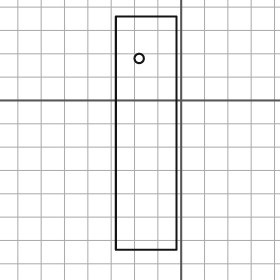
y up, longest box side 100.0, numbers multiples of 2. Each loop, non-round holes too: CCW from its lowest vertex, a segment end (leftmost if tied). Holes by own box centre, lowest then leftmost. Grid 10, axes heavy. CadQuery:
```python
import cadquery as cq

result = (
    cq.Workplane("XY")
    .moveTo(-28.0, -64.0)
    .lineTo(-2.0, -64.0)
    .lineTo(-2.0, 36.0)
    .lineTo(-28.0, 36.0)
    .close()
    .moveTo(-18.0, 18.0)
    .circle(2.0)
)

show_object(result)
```